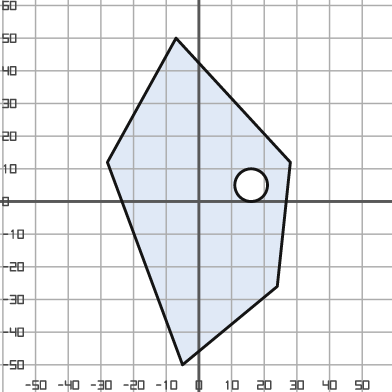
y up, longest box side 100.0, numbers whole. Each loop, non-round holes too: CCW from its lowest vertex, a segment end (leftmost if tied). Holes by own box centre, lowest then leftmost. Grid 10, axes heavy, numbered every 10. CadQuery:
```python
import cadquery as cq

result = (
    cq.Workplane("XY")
    .moveTo(-5.0, -50.0)
    .lineTo(24.0, -26.0)
    .lineTo(28.0, 12.0)
    .lineTo(-7.0, 50.0)
    .lineTo(-28.0, 12.0)
    .close()
    .moveTo(16.0, 5.0)
    .circle(5.0)
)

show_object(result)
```